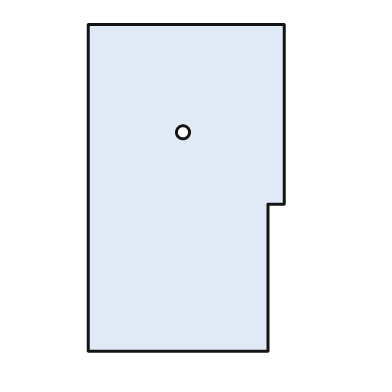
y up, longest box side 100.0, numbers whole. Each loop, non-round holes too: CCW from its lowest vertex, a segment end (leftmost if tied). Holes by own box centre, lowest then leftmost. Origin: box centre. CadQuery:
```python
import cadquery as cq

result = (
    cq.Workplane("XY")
    .moveTo(-30.0, -50.0)
    .lineTo(25.0, -50.0)
    .lineTo(25.0, -5.0)
    .lineTo(30.0, -5.0)
    .lineTo(30.0, 50.0)
    .lineTo(-30.0, 50.0)
    .close()
    .moveTo(-1.0, 17.0)
    .circle(2.0)
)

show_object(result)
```